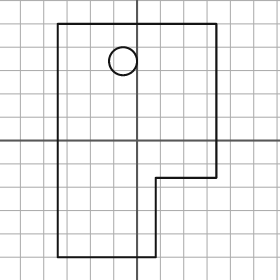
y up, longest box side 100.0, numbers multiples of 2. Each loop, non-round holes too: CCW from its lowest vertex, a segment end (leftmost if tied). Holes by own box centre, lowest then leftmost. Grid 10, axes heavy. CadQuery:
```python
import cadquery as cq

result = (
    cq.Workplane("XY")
    .moveTo(-34.0, -50.0)
    .lineTo(8.0, -50.0)
    .lineTo(8.0, -16.0)
    .lineTo(34.0, -16.0)
    .lineTo(34.0, 50.0)
    .lineTo(-34.0, 50.0)
    .close()
    .moveTo(-6.0, 34.0)
    .circle(6.0)
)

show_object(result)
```